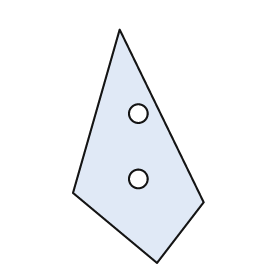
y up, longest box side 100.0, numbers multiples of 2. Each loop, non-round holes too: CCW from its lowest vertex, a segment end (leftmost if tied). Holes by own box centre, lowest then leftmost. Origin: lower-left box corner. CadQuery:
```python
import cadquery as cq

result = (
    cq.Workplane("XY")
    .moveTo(36.0, 0.0)
    .lineTo(56.0, 26.0)
    .lineTo(20.0, 100.0)
    .lineTo(0.0, 30.0)
    .close()
    .moveTo(28.0, 36.0)
    .circle(4.0)
    .moveTo(28.0, 64.0)
    .circle(4.0)
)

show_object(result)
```